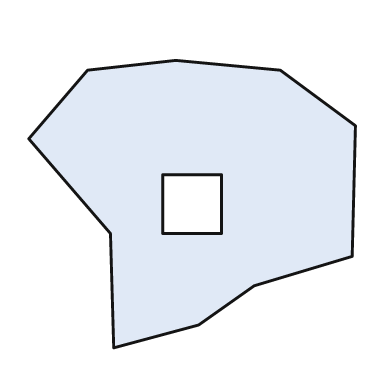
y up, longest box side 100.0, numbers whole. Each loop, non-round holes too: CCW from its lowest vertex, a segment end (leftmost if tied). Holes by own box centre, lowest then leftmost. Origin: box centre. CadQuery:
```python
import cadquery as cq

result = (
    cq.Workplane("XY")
    .moveTo(-24.0, -44.0)
    .lineTo(2.0, -37.0)
    .lineTo(19.0, -25.0)
    .lineTo(49.0, -16.0)
    .lineTo(50.0, 24.0)
    .lineTo(27.0, 41.0)
    .lineTo(-5.0, 44.0)
    .lineTo(-32.0, 41.0)
    .lineTo(-50.0, 20.0)
    .lineTo(-25.0, -9.0)
    .close()
    .moveTo(-9.0, -9.0)
    .lineTo(9.0, -9.0)
    .lineTo(9.0, 9.0)
    .lineTo(-9.0, 9.0)
    .close()
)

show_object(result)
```